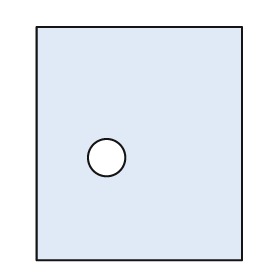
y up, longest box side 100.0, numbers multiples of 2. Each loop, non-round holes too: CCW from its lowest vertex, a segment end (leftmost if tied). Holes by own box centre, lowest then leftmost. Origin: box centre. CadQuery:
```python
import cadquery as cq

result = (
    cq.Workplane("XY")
    .moveTo(-44.0, -50.0)
    .lineTo(44.0, -50.0)
    .lineTo(44.0, 50.0)
    .lineTo(-44.0, 50.0)
    .close()
    .moveTo(-14.0, -6.0)
    .circle(8.0)
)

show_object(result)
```